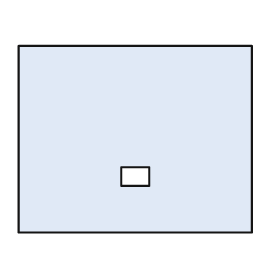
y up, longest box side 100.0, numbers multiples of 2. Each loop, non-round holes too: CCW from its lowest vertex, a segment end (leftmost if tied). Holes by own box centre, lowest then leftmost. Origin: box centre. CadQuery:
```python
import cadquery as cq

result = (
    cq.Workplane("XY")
    .moveTo(-50.0, -40.0)
    .lineTo(50.0, -40.0)
    .lineTo(50.0, 40.0)
    .lineTo(-50.0, 40.0)
    .close()
    .moveTo(-6.0, -20.0)
    .lineTo(6.0, -20.0)
    .lineTo(6.0, -12.0)
    .lineTo(-6.0, -12.0)
    .close()
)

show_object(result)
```